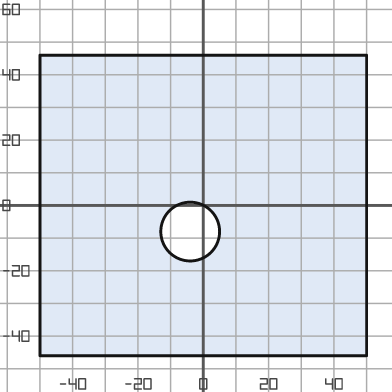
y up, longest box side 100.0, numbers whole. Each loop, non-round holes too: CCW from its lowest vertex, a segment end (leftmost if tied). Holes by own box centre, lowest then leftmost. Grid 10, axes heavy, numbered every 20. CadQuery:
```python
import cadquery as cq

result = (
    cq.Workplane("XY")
    .moveTo(-50.0, -46.0)
    .lineTo(50.0, -46.0)
    .lineTo(50.0, 46.0)
    .lineTo(-50.0, 46.0)
    .close()
    .moveTo(-4.0, -8.0)
    .circle(9.0)
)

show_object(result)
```